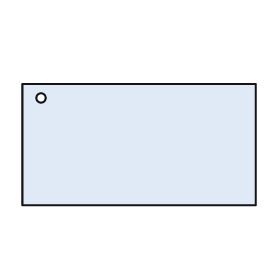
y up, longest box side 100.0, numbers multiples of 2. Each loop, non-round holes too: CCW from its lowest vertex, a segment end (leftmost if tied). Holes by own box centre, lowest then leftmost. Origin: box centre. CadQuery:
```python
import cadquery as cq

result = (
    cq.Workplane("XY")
    .moveTo(-50.0, -26.0)
    .lineTo(50.0, -26.0)
    .lineTo(50.0, 26.0)
    .lineTo(-50.0, 26.0)
    .close()
    .moveTo(-42.0, 20.0)
    .circle(2.0)
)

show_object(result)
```